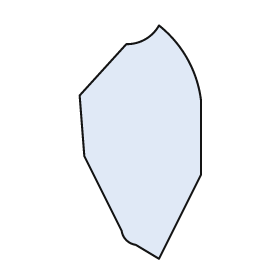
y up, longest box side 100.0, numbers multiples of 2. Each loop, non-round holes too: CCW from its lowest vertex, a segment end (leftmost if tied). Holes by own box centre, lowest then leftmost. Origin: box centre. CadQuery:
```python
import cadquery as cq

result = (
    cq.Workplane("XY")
    .moveTo(8.0, -50.0)
    .lineTo(26.0, -14.0)
    .lineTo(26.0, 18.0)
    .threePointArc((20.0, 36.0), (8.0, 50.0))
    .threePointArc((2.0, 44.0), (-6.0, 42.0))
    .lineTo(-26.0, 20.0)
    .lineTo(-24.0, -6.0)
    .lineTo(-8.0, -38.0)
    .threePointArc((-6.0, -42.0), (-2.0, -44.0))
    .close()
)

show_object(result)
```